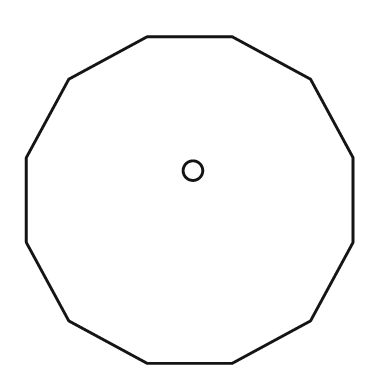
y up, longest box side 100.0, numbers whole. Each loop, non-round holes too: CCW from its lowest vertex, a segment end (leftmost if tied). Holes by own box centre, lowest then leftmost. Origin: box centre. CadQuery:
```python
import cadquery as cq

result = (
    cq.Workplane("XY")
    .moveTo(-13.0, -50.0)
    .lineTo(13.0, -50.0)
    .lineTo(37.0, -37.0)
    .lineTo(50.0, -13.0)
    .lineTo(50.0, 13.0)
    .lineTo(37.0, 37.0)
    .lineTo(13.0, 50.0)
    .lineTo(-13.0, 50.0)
    .lineTo(-37.0, 37.0)
    .lineTo(-50.0, 13.0)
    .lineTo(-50.0, -13.0)
    .lineTo(-37.0, -37.0)
    .close()
    .moveTo(1.0, 9.0)
    .circle(3.0)
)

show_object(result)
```